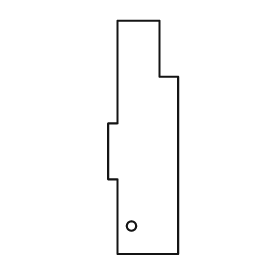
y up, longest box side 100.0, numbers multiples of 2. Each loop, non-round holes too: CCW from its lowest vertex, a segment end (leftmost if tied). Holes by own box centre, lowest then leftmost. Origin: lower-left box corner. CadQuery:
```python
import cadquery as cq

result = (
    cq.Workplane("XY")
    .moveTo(4.0, 0.0)
    .lineTo(30.0, 0.0)
    .lineTo(30.0, 76.0)
    .lineTo(22.0, 76.0)
    .lineTo(22.0, 100.0)
    .lineTo(4.0, 100.0)
    .lineTo(4.0, 56.0)
    .lineTo(0.0, 56.0)
    .lineTo(0.0, 32.0)
    .lineTo(4.0, 32.0)
    .close()
    .moveTo(10.0, 12.0)
    .circle(2.0)
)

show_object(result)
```